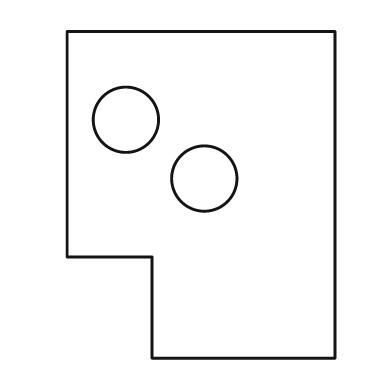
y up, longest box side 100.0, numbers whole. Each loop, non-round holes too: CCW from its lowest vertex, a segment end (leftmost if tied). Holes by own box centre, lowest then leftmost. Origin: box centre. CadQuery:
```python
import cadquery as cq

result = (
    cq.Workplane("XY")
    .moveTo(-15.0, -50.0)
    .lineTo(41.0, -50.0)
    .lineTo(41.0, 50.0)
    .lineTo(-41.0, 50.0)
    .lineTo(-41.0, -19.0)
    .lineTo(-15.0, -19.0)
    .close()
    .moveTo(1.0, 5.0)
    .circle(10.0)
    .moveTo(-23.0, 23.0)
    .circle(10.0)
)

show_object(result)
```